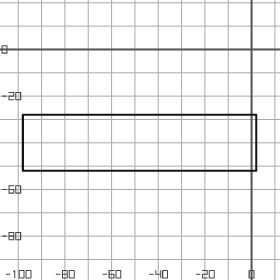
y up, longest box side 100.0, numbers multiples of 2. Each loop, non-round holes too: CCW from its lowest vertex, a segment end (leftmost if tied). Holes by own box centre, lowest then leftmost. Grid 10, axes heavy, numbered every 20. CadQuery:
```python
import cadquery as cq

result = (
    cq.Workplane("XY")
    .moveTo(-98.0, -52.0)
    .lineTo(2.0, -52.0)
    .lineTo(2.0, -28.0)
    .lineTo(-98.0, -28.0)
    .close()
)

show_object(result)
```